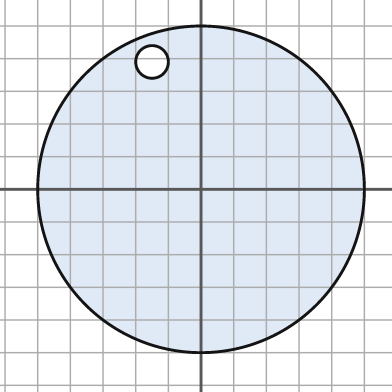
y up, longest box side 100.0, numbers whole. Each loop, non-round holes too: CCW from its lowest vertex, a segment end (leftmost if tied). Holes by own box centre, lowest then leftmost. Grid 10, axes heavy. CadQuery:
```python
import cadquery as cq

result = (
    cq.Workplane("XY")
    .moveTo(0.0, 0.0)
    .circle(50.0)
    .moveTo(-15.0, 39.0)
    .circle(5.0)
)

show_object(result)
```